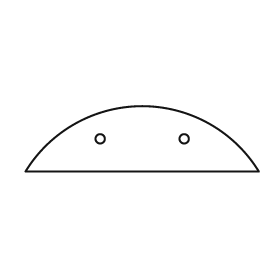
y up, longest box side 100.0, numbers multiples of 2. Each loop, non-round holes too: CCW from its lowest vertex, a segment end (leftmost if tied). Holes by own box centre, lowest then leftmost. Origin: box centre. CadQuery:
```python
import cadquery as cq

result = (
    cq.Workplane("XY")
    .moveTo(-50.0, -14.0)
    .lineTo(50.0, -14.0)
    .threePointArc((0.0, 14.0), (-50.0, -14.0))
    .close()
    .moveTo(-18.0, 0.0)
    .circle(2.0)
    .moveTo(18.0, 0.0)
    .circle(2.0)
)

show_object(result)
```